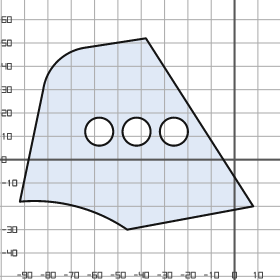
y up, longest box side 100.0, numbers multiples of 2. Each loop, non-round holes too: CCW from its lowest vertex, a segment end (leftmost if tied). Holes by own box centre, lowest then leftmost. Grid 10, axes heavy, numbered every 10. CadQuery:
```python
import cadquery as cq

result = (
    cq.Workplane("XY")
    .moveTo(-46.0, -30.0)
    .lineTo(8.0, -20.0)
    .lineTo(-38.0, 52.0)
    .lineTo(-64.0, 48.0)
    .threePointArc((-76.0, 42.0), (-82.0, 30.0))
    .lineTo(-92.0, -18.0)
    .threePointArc((-68.0, -20.0), (-46.0, -30.0))
    .close()
    .moveTo(-58.0, 12.0)
    .circle(6.0)
    .moveTo(-42.0, 12.0)
    .circle(6.0)
    .moveTo(-26.0, 12.0)
    .circle(6.0)
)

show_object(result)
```